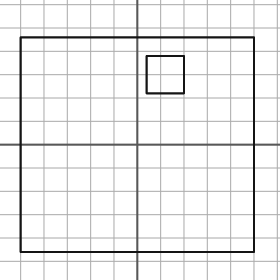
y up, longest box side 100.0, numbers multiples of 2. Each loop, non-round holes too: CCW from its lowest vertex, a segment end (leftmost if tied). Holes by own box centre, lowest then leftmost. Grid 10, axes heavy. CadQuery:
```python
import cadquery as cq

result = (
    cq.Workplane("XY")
    .moveTo(-50.0, -46.0)
    .lineTo(50.0, -46.0)
    .lineTo(50.0, 46.0)
    .lineTo(-50.0, 46.0)
    .close()
    .moveTo(4.0, 22.0)
    .lineTo(20.0, 22.0)
    .lineTo(20.0, 38.0)
    .lineTo(4.0, 38.0)
    .close()
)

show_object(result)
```